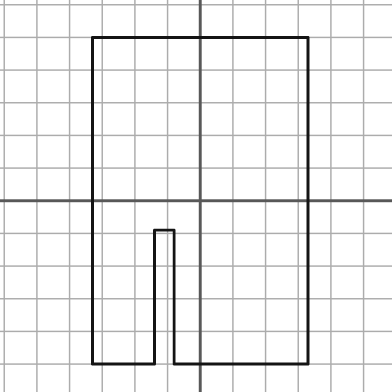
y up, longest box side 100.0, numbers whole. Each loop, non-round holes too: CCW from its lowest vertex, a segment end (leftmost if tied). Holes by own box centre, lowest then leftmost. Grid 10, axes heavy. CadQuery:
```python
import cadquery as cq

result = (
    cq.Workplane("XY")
    .moveTo(-33.0, -50.0)
    .lineTo(-14.0, -50.0)
    .lineTo(-14.0, -9.0)
    .lineTo(-8.0, -9.0)
    .lineTo(-8.0, -50.0)
    .lineTo(33.0, -50.0)
    .lineTo(33.0, 50.0)
    .lineTo(-33.0, 50.0)
    .close()
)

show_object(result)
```